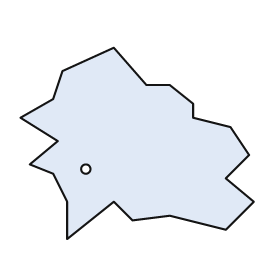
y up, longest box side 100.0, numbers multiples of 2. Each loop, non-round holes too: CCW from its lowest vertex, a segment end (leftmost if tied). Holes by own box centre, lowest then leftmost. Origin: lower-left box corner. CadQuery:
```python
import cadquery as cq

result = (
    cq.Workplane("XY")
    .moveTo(20.0, 0.0)
    .lineTo(40.0, 16.0)
    .lineTo(48.0, 8.0)
    .lineTo(64.0, 10.0)
    .lineTo(88.0, 4.0)
    .lineTo(100.0, 16.0)
    .lineTo(88.0, 26.0)
    .lineTo(98.0, 36.0)
    .lineTo(90.0, 48.0)
    .lineTo(74.0, 52.0)
    .lineTo(74.0, 58.0)
    .lineTo(64.0, 66.0)
    .lineTo(54.0, 66.0)
    .lineTo(40.0, 82.0)
    .lineTo(18.0, 72.0)
    .lineTo(14.0, 60.0)
    .lineTo(0.0, 52.0)
    .lineTo(16.0, 42.0)
    .lineTo(4.0, 32.0)
    .lineTo(14.0, 28.0)
    .lineTo(20.0, 16.0)
    .close()
    .moveTo(28.0, 30.0)
    .circle(2.0)
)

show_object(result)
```